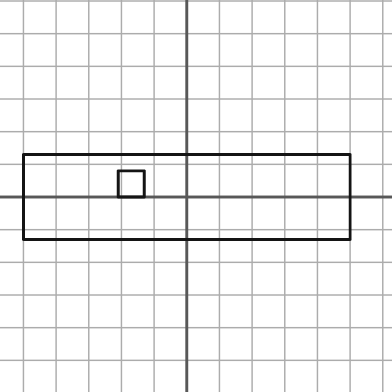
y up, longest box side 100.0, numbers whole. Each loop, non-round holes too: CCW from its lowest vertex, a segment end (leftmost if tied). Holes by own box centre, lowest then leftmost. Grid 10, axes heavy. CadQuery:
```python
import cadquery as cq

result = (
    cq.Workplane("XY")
    .moveTo(-50.0, -13.0)
    .lineTo(50.0, -13.0)
    .lineTo(50.0, 13.0)
    .lineTo(-50.0, 13.0)
    .close()
    .moveTo(-21.0, 0.0)
    .lineTo(-13.0, 0.0)
    .lineTo(-13.0, 8.0)
    .lineTo(-21.0, 8.0)
    .close()
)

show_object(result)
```